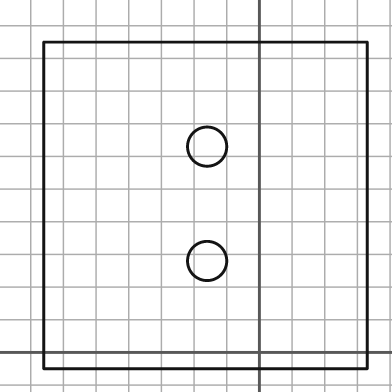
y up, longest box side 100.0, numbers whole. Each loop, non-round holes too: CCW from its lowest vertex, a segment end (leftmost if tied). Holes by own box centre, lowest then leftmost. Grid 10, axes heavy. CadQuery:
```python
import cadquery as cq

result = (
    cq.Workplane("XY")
    .moveTo(-66.0, -5.0)
    .lineTo(33.0, -5.0)
    .lineTo(33.0, 95.0)
    .lineTo(-66.0, 95.0)
    .close()
    .moveTo(-16.0, 28.0)
    .circle(6.0)
    .moveTo(-16.0, 63.0)
    .circle(6.0)
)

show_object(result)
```